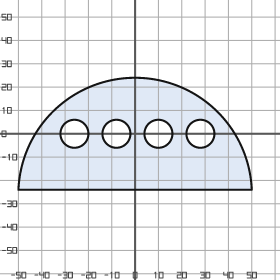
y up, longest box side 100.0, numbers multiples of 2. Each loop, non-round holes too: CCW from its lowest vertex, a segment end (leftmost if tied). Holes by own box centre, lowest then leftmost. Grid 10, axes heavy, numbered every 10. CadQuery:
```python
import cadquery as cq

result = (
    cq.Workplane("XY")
    .moveTo(-50.0, -24.0)
    .lineTo(50.0, -24.0)
    .threePointArc((0.0, 24.0), (-50.0, -24.0))
    .close()
    .moveTo(-26.0, 0.0)
    .circle(6.0)
    .moveTo(-8.0, 0.0)
    .circle(6.0)
    .moveTo(10.0, 0.0)
    .circle(6.0)
    .moveTo(28.0, 0.0)
    .circle(6.0)
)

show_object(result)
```